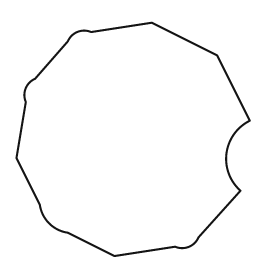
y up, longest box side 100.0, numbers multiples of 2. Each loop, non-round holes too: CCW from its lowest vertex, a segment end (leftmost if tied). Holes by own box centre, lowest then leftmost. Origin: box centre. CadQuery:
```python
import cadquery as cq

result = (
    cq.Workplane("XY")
    .moveTo(-8.0, -50.0)
    .lineTo(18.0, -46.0)
    .threePointArc((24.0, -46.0), (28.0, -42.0))
    .lineTo(46.0, -22.0)
    .threePointArc((40.0, -6.0), (50.0, 8.0))
    .lineTo(36.0, 36.0)
    .lineTo(8.0, 50.0)
    .lineTo(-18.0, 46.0)
    .threePointArc((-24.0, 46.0), (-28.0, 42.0))
    .lineTo(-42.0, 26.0)
    .threePointArc((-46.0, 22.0), (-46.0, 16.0))
    .lineTo(-50.0, -8.0)
    .lineTo(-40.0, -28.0)
    .threePointArc((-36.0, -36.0), (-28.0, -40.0))
    .close()
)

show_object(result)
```